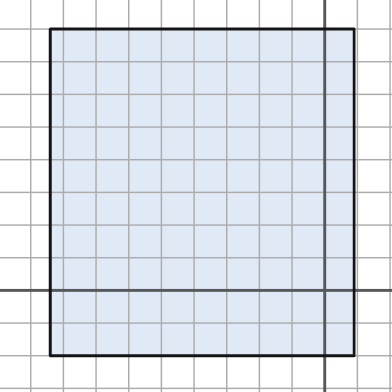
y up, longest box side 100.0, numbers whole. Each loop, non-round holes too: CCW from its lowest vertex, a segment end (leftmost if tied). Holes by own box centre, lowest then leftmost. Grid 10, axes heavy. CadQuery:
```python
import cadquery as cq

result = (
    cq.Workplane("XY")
    .moveTo(-84.0, -20.0)
    .lineTo(9.0, -20.0)
    .lineTo(9.0, 80.0)
    .lineTo(-84.0, 80.0)
    .close()
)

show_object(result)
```